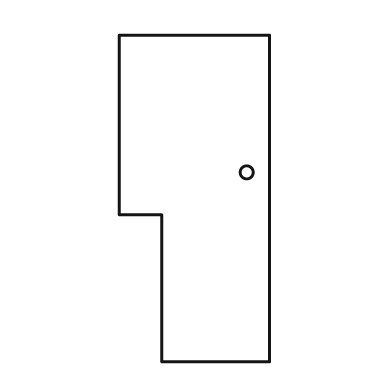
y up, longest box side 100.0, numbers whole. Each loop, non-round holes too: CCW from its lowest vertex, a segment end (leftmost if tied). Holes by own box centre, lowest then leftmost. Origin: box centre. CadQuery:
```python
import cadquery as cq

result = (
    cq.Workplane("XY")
    .moveTo(-10.0, -50.0)
    .lineTo(23.0, -50.0)
    .lineTo(23.0, 50.0)
    .lineTo(-23.0, 50.0)
    .lineTo(-23.0, -5.0)
    .lineTo(-10.0, -5.0)
    .close()
    .moveTo(16.0, 8.0)
    .circle(2.0)
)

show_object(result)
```